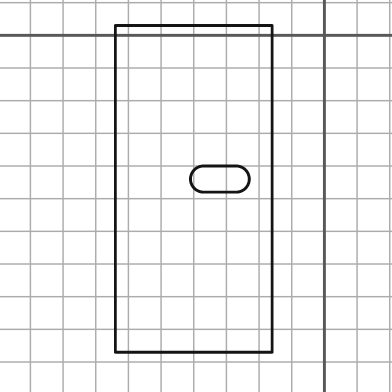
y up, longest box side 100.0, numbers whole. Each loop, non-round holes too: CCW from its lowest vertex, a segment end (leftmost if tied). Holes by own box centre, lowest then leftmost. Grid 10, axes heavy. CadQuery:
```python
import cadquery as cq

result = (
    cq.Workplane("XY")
    .moveTo(-64.0, -97.0)
    .lineTo(-16.0, -97.0)
    .lineTo(-16.0, 3.0)
    .lineTo(-64.0, 3.0)
    .close()
    .moveTo(-37.0, -48.0)
    .lineTo(-27.0, -48.0)
    .threePointArc((-23.0, -44.0), (-27.0, -40.0))
    .lineTo(-37.0, -40.0)
    .threePointArc((-41.0, -44.0), (-37.0, -48.0))
    .close()
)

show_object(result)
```